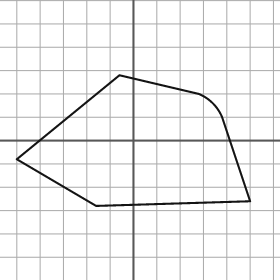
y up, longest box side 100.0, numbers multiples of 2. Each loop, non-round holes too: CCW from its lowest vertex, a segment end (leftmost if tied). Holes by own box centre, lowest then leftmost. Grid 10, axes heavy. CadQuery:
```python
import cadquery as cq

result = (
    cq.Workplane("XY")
    .moveTo(-16.0, -28.0)
    .lineTo(50.0, -26.0)
    .lineTo(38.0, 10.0)
    .threePointArc((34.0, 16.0), (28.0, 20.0))
    .lineTo(-6.0, 28.0)
    .lineTo(-50.0, -8.0)
    .close()
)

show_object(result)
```